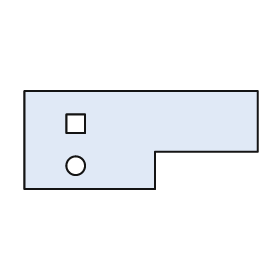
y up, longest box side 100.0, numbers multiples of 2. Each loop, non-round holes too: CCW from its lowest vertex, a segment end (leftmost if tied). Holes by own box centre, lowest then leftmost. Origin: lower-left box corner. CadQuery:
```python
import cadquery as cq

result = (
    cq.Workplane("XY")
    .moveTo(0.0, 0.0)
    .lineTo(56.0, 0.0)
    .lineTo(56.0, 16.0)
    .lineTo(100.0, 16.0)
    .lineTo(100.0, 42.0)
    .lineTo(0.0, 42.0)
    .close()
    .moveTo(22.0, 10.0)
    .circle(4.0)
    .moveTo(18.0, 24.0)
    .lineTo(26.0, 24.0)
    .lineTo(26.0, 32.0)
    .lineTo(18.0, 32.0)
    .close()
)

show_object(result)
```